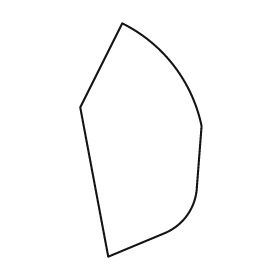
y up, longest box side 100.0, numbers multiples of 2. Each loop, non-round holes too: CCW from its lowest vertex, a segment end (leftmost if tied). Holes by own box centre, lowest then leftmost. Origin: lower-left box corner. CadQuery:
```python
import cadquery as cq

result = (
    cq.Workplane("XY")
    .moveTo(12.0, 0.0)
    .lineTo(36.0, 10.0)
    .threePointArc((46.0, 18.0), (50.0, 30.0))
    .lineTo(52.0, 56.0)
    .threePointArc((40.0, 82.0), (18.0, 100.0))
    .lineTo(0.0, 64.0)
    .close()
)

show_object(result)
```